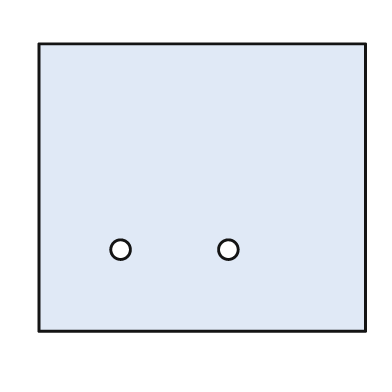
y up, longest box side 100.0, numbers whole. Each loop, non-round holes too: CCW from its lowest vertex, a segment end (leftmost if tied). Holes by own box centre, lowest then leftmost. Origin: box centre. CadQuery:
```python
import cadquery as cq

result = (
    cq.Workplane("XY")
    .moveTo(-50.0, -44.0)
    .lineTo(50.0, -44.0)
    .lineTo(50.0, 44.0)
    .lineTo(-50.0, 44.0)
    .close()
    .moveTo(-25.0, -19.0)
    .circle(3.0)
    .moveTo(8.0, -19.0)
    .circle(3.0)
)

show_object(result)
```